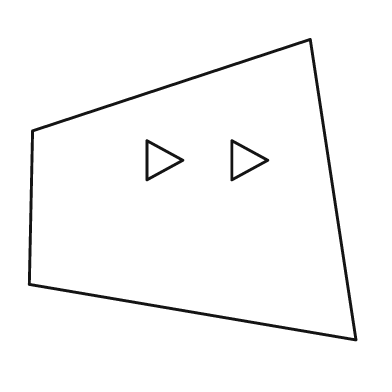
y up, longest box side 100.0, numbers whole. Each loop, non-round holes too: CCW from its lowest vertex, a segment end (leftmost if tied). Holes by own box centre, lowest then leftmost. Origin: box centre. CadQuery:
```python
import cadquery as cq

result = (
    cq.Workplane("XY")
    .moveTo(50.0, -46.0)
    .lineTo(36.0, 46.0)
    .lineTo(-49.0, 18.0)
    .lineTo(-50.0, -29.0)
    .close()
    .moveTo(-14.0, 3.0)
    .lineTo(-3.0, 9.0)
    .lineTo(-14.0, 15.0)
    .close()
    .moveTo(12.0, 3.0)
    .lineTo(23.0, 9.0)
    .lineTo(12.0, 15.0)
    .close()
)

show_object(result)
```